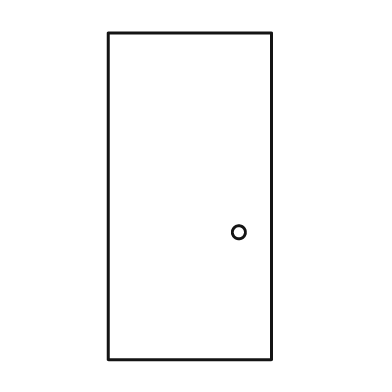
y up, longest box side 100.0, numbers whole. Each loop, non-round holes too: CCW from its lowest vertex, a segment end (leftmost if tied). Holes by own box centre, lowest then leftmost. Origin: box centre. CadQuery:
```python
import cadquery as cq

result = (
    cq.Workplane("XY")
    .moveTo(-25.0, -50.0)
    .lineTo(25.0, -50.0)
    .lineTo(25.0, 50.0)
    .lineTo(-25.0, 50.0)
    .close()
    .moveTo(15.0, -11.0)
    .circle(2.0)
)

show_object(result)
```